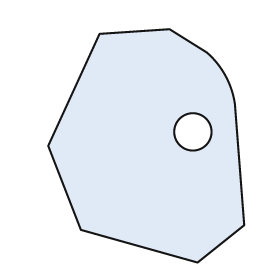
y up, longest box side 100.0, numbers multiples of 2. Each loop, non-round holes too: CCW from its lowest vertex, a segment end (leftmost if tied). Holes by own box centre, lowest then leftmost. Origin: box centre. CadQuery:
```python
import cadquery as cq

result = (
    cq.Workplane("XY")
    .moveTo(22.0, -50.0)
    .lineTo(42.0, -34.0)
    .lineTo(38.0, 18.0)
    .threePointArc((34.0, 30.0), (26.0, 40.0))
    .lineTo(10.0, 50.0)
    .lineTo(-20.0, 48.0)
    .lineTo(-42.0, 0.0)
    .lineTo(-28.0, -36.0)
    .close()
    .moveTo(20.0, 6.0)
    .circle(8.0)
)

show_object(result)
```